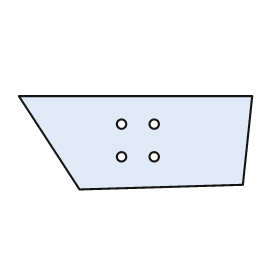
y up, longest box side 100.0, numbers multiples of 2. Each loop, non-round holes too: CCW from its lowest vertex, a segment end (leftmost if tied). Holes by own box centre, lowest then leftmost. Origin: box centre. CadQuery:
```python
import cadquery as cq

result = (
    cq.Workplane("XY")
    .moveTo(-24.0, -20.0)
    .lineTo(46.0, -18.0)
    .lineTo(50.0, 20.0)
    .lineTo(-50.0, 20.0)
    .close()
    .moveTo(-6.0, -6.0)
    .circle(2.0)
    .moveTo(8.0, -6.0)
    .circle(2.0)
    .moveTo(-6.0, 8.0)
    .circle(2.0)
    .moveTo(8.0, 8.0)
    .circle(2.0)
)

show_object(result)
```